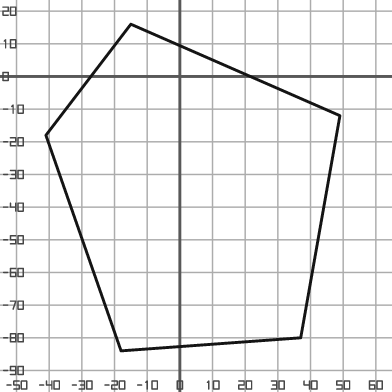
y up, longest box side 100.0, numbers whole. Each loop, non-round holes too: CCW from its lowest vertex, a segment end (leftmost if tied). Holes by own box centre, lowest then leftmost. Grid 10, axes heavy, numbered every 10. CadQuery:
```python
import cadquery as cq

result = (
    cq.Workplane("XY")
    .moveTo(-18.0, -84.0)
    .lineTo(37.0, -80.0)
    .lineTo(49.0, -12.0)
    .lineTo(-15.0, 16.0)
    .lineTo(-41.0, -18.0)
    .close()
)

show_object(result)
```